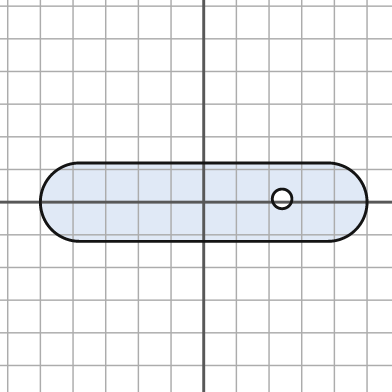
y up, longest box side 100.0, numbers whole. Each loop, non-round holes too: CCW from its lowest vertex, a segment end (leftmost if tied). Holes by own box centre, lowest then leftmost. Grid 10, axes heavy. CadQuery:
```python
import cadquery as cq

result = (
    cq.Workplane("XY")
    .moveTo(-38.0, -12.0)
    .lineTo(38.0, -12.0)
    .threePointArc((50.0, 0.0), (38.0, 12.0))
    .lineTo(-38.0, 12.0)
    .threePointArc((-50.0, 0.0), (-38.0, -12.0))
    .close()
    .moveTo(24.0, 1.0)
    .circle(3.0)
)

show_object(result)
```